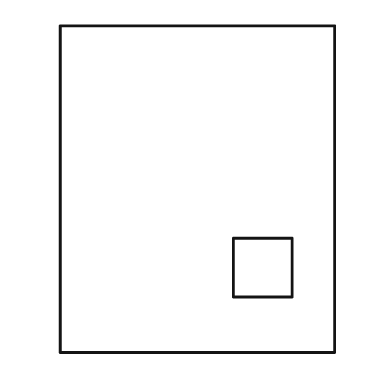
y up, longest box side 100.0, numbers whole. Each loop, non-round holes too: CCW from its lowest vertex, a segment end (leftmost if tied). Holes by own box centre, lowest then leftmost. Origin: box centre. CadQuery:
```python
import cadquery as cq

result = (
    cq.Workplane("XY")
    .moveTo(-42.0, -50.0)
    .lineTo(42.0, -50.0)
    .lineTo(42.0, 50.0)
    .lineTo(-42.0, 50.0)
    .close()
    .moveTo(11.0, -33.0)
    .lineTo(29.0, -33.0)
    .lineTo(29.0, -15.0)
    .lineTo(11.0, -15.0)
    .close()
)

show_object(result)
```